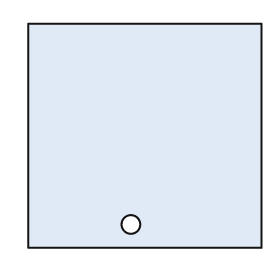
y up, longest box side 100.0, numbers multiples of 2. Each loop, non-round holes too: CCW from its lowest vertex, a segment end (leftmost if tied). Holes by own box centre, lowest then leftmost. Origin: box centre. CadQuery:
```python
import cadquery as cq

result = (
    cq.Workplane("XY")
    .moveTo(-50.0, -48.0)
    .lineTo(50.0, -48.0)
    .lineTo(50.0, 48.0)
    .lineTo(-50.0, 48.0)
    .close()
    .moveTo(-6.0, -38.0)
    .circle(4.0)
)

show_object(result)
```